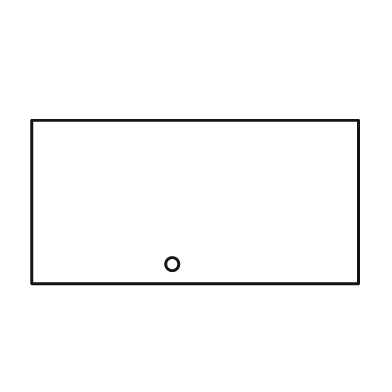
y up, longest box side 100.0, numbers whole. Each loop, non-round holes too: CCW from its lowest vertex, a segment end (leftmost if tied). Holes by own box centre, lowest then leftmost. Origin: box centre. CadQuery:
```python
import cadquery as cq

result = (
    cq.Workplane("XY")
    .moveTo(-50.0, -25.0)
    .lineTo(50.0, -25.0)
    .lineTo(50.0, 25.0)
    .lineTo(-50.0, 25.0)
    .close()
    .moveTo(-7.0, -19.0)
    .circle(2.0)
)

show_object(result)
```